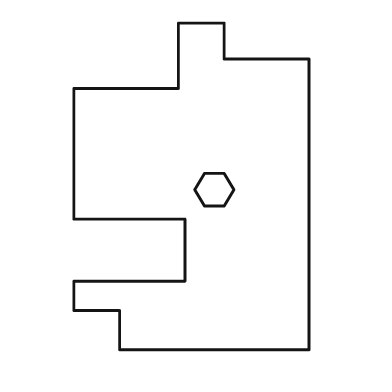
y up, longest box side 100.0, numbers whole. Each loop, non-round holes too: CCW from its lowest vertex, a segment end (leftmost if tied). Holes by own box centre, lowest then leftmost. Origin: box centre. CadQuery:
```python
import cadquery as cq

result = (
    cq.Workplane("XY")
    .moveTo(-22.0, -50.0)
    .lineTo(36.0, -50.0)
    .lineTo(36.0, 39.0)
    .lineTo(10.0, 39.0)
    .lineTo(10.0, 50.0)
    .lineTo(-4.0, 50.0)
    .lineTo(-4.0, 30.0)
    .lineTo(-36.0, 30.0)
    .lineTo(-36.0, -10.0)
    .lineTo(-2.0, -10.0)
    .lineTo(-2.0, -29.0)
    .lineTo(-36.0, -29.0)
    .lineTo(-36.0, -38.0)
    .lineTo(-22.0, -38.0)
    .close()
    .moveTo(4.0, -6.0)
    .lineTo(10.0, -6.0)
    .lineTo(13.0, -1.0)
    .lineTo(10.0, 4.0)
    .lineTo(4.0, 4.0)
    .lineTo(1.0, -1.0)
    .close()
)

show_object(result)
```